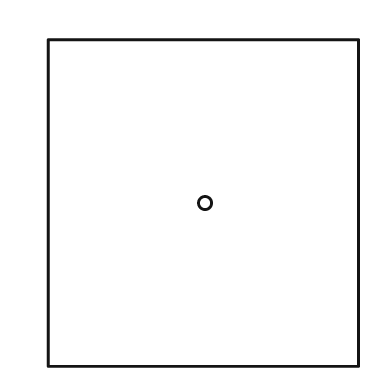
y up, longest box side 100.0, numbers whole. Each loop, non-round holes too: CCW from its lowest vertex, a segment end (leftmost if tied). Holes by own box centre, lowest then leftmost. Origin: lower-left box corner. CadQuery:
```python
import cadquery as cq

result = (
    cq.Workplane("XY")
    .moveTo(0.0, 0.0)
    .lineTo(95.0, 0.0)
    .lineTo(95.0, 100.0)
    .lineTo(0.0, 100.0)
    .close()
    .moveTo(48.0, 50.0)
    .circle(2.0)
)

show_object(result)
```